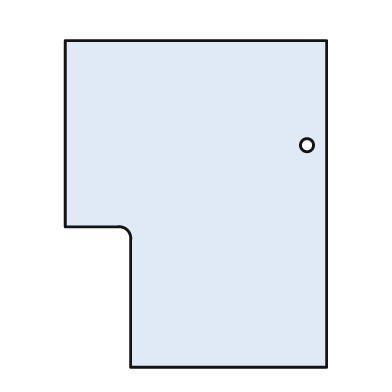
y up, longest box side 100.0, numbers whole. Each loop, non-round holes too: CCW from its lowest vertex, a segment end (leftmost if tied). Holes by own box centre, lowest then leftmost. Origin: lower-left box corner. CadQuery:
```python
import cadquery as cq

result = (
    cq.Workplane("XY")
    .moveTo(20.0, 0.0)
    .lineTo(80.0, 0.0)
    .lineTo(80.0, 100.0)
    .lineTo(0.0, 100.0)
    .lineTo(0.0, 43.0)
    .lineTo(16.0, 43.0)
    .threePointArc((19.0, 42.0), (20.0, 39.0))
    .close()
    .moveTo(74.0, 68.0)
    .circle(2.0)
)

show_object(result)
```